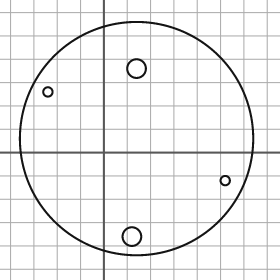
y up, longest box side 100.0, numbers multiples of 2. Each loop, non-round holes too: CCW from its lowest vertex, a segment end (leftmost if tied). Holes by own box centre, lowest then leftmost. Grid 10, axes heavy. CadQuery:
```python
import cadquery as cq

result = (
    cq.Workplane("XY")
    .moveTo(14.0, 6.0)
    .circle(50.0)
    .moveTo(12.0, -36.0)
    .circle(4.0)
    .moveTo(52.0, -12.0)
    .circle(2.0)
    .moveTo(-24.0, 26.0)
    .circle(2.0)
    .moveTo(14.0, 36.0)
    .circle(4.0)
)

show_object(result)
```